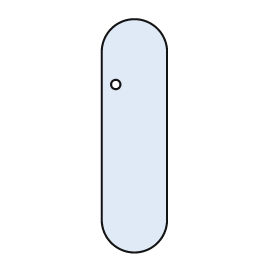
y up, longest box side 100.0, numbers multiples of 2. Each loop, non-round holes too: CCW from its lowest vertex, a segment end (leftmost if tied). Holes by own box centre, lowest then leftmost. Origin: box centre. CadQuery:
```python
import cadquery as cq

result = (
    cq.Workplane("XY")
    .moveTo(-14.0, -36.0)
    .threePointArc((0.0, -50.0), (14.0, -36.0))
    .lineTo(14.0, 36.0)
    .threePointArc((0.0, 50.0), (-14.0, 36.0))
    .close()
    .moveTo(-8.0, 22.0)
    .circle(2.0)
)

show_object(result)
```